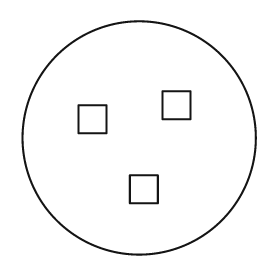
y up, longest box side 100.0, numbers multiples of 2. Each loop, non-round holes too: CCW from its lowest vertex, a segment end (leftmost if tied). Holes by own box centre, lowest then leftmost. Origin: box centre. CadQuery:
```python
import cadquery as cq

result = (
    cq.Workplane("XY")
    .moveTo(0.0, 0.0)
    .circle(50.0)
    .moveTo(-4.0, -28.0)
    .lineTo(8.0, -28.0)
    .lineTo(8.0, -16.0)
    .lineTo(-4.0, -16.0)
    .close()
    .moveTo(-26.0, 2.0)
    .lineTo(-14.0, 2.0)
    .lineTo(-14.0, 14.0)
    .lineTo(-26.0, 14.0)
    .close()
    .moveTo(10.0, 8.0)
    .lineTo(22.0, 8.0)
    .lineTo(22.0, 20.0)
    .lineTo(10.0, 20.0)
    .close()
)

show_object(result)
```